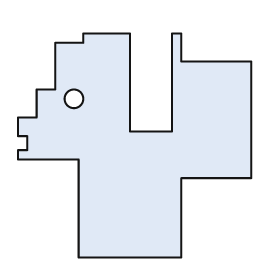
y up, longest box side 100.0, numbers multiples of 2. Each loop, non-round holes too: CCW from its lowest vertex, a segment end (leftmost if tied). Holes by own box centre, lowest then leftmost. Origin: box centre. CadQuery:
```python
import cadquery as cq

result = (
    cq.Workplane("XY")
    .moveTo(-24.0, -48.0)
    .lineTo(20.0, -48.0)
    .lineTo(20.0, -14.0)
    .lineTo(50.0, -14.0)
    .lineTo(50.0, 36.0)
    .lineTo(20.0, 36.0)
    .lineTo(20.0, 48.0)
    .lineTo(16.0, 48.0)
    .lineTo(16.0, 6.0)
    .lineTo(-2.0, 6.0)
    .lineTo(-2.0, 48.0)
    .lineTo(-22.0, 48.0)
    .lineTo(-22.0, 44.0)
    .lineTo(-34.0, 44.0)
    .lineTo(-34.0, 24.0)
    .lineTo(-42.0, 24.0)
    .lineTo(-42.0, 12.0)
    .lineTo(-50.0, 12.0)
    .lineTo(-50.0, 4.0)
    .lineTo(-46.0, 4.0)
    .lineTo(-46.0, -2.0)
    .lineTo(-50.0, -2.0)
    .lineTo(-50.0, -6.0)
    .lineTo(-24.0, -6.0)
    .close()
    .moveTo(-26.0, 20.0)
    .circle(4.0)
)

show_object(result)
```